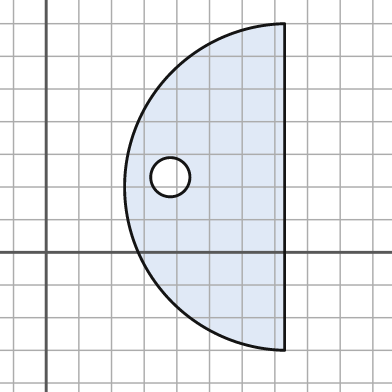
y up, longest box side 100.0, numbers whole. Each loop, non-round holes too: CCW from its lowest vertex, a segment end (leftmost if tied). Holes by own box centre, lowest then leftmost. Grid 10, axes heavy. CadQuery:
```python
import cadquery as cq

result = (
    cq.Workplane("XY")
    .moveTo(73.0, -30.0)
    .lineTo(73.0, 70.0)
    .threePointArc((24.0, 20.0), (73.0, -30.0))
    .close()
    .moveTo(38.0, 23.0)
    .circle(6.0)
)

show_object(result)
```